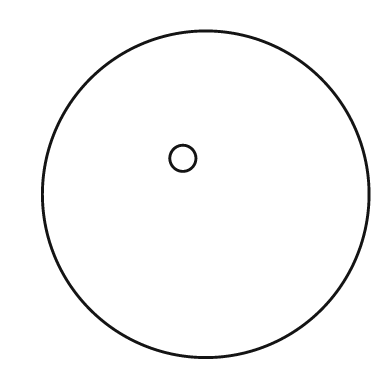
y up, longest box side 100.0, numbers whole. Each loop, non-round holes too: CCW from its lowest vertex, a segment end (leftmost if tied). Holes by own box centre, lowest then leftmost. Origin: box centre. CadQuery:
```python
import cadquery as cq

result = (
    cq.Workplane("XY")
    .moveTo(0.0, 0.0)
    .circle(50.0)
    .moveTo(-7.0, 11.0)
    .circle(4.0)
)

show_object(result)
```